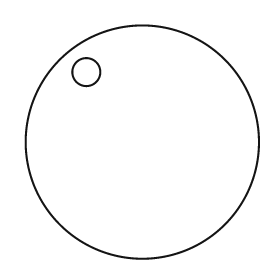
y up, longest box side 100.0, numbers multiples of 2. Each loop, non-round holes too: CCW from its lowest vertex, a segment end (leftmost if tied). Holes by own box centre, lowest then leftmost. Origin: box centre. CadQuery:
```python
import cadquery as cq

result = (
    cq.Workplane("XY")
    .moveTo(0.0, 0.0)
    .circle(50.0)
    .moveTo(-24.0, 30.0)
    .circle(6.0)
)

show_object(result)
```